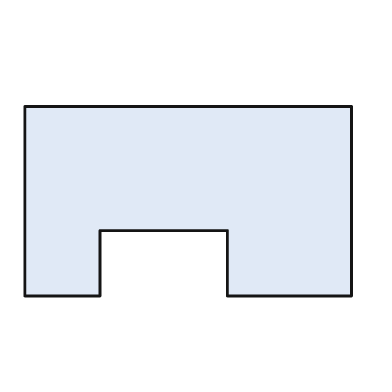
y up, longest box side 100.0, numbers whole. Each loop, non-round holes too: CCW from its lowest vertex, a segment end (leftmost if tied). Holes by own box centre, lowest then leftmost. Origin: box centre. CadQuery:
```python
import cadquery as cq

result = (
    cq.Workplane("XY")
    .moveTo(-50.0, -29.0)
    .lineTo(-27.0, -29.0)
    .lineTo(-27.0, -9.0)
    .lineTo(12.0, -9.0)
    .lineTo(12.0, -29.0)
    .lineTo(50.0, -29.0)
    .lineTo(50.0, 29.0)
    .lineTo(-50.0, 29.0)
    .close()
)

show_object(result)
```